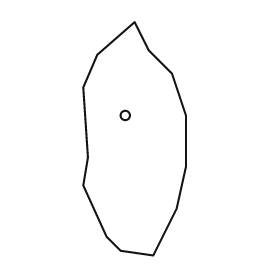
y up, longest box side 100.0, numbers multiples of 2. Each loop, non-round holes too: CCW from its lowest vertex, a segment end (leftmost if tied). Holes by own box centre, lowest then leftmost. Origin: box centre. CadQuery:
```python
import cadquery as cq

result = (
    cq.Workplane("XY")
    .moveTo(8.0, -50.0)
    .lineTo(18.0, -30.0)
    .lineTo(22.0, -12.0)
    .lineTo(22.0, 10.0)
    .lineTo(16.0, 28.0)
    .lineTo(6.0, 38.0)
    .lineTo(0.0, 50.0)
    .lineTo(-16.0, 36.0)
    .lineTo(-22.0, 22.0)
    .lineTo(-20.0, -8.0)
    .lineTo(-22.0, -20.0)
    .lineTo(-12.0, -42.0)
    .lineTo(-6.0, -48.0)
    .close()
    .moveTo(-4.0, 10.0)
    .circle(2.0)
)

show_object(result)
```